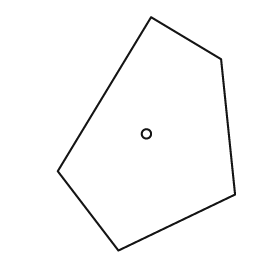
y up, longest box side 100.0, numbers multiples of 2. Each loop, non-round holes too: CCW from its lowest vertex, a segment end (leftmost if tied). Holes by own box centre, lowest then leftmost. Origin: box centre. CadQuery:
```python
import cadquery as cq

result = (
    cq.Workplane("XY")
    .moveTo(-12.0, -50.0)
    .lineTo(38.0, -26.0)
    .lineTo(32.0, 32.0)
    .lineTo(2.0, 50.0)
    .lineTo(-38.0, -16.0)
    .close()
    .moveTo(0.0, 0.0)
    .circle(2.0)
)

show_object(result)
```